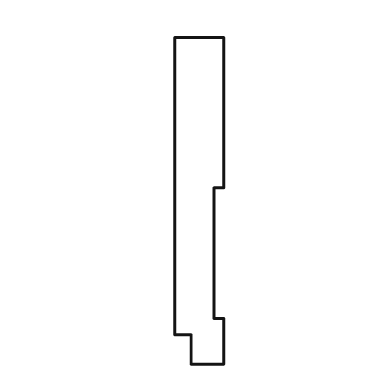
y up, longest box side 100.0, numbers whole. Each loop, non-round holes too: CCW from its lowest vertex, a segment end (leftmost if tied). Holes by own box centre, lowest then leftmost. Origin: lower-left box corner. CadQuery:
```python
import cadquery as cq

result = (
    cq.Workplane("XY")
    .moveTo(5.0, 0.0)
    .lineTo(15.0, 0.0)
    .lineTo(15.0, 14.0)
    .lineTo(12.0, 14.0)
    .lineTo(12.0, 54.0)
    .lineTo(15.0, 54.0)
    .lineTo(15.0, 100.0)
    .lineTo(0.0, 100.0)
    .lineTo(0.0, 9.0)
    .lineTo(5.0, 9.0)
    .close()
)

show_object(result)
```